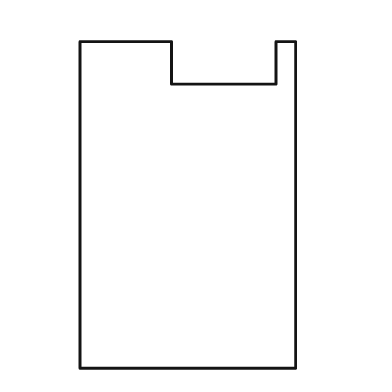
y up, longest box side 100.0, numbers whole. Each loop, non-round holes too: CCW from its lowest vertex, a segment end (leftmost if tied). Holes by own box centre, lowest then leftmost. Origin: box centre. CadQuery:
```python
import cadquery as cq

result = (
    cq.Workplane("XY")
    .moveTo(-33.0, -50.0)
    .lineTo(33.0, -50.0)
    .lineTo(33.0, 50.0)
    .lineTo(27.0, 50.0)
    .lineTo(27.0, 37.0)
    .lineTo(-5.0, 37.0)
    .lineTo(-5.0, 50.0)
    .lineTo(-33.0, 50.0)
    .close()
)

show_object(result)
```